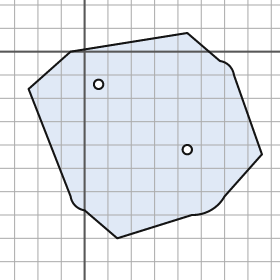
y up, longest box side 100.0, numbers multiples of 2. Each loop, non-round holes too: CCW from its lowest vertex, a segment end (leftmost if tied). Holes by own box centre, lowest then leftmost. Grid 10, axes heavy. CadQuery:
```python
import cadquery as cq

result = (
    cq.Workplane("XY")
    .moveTo(14.0, -80.0)
    .lineTo(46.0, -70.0)
    .threePointArc((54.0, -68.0), (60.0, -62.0))
    .lineTo(76.0, -44.0)
    .lineTo(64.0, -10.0)
    .threePointArc((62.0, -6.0), (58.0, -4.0))
    .lineTo(44.0, 8.0)
    .lineTo(-6.0, 0.0)
    .lineTo(-24.0, -16.0)
    .lineTo(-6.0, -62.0)
    .threePointArc((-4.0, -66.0), (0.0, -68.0))
    .close()
    .moveTo(44.0, -42.0)
    .circle(2.0)
    .moveTo(6.0, -14.0)
    .circle(2.0)
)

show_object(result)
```